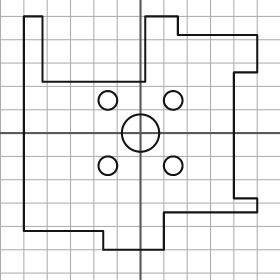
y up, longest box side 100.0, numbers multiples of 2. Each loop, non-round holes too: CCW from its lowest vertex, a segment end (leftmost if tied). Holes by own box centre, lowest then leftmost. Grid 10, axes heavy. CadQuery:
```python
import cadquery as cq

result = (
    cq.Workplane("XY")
    .moveTo(-16.0, -50.0)
    .lineTo(10.0, -50.0)
    .lineTo(10.0, -34.0)
    .lineTo(50.0, -34.0)
    .lineTo(50.0, -28.0)
    .lineTo(40.0, -28.0)
    .lineTo(40.0, 26.0)
    .lineTo(50.0, 26.0)
    .lineTo(50.0, 42.0)
    .lineTo(16.0, 42.0)
    .lineTo(16.0, 50.0)
    .lineTo(2.0, 50.0)
    .lineTo(2.0, 22.0)
    .lineTo(-42.0, 22.0)
    .lineTo(-42.0, 50.0)
    .lineTo(-50.0, 50.0)
    .lineTo(-50.0, -42.0)
    .lineTo(-16.0, -42.0)
    .close()
    .moveTo(-14.0, -14.0)
    .circle(4.0)
    .moveTo(14.0, -14.0)
    .circle(4.0)
    .moveTo(0.0, 0.0)
    .circle(8.0)
    .moveTo(-14.0, 14.0)
    .circle(4.0)
    .moveTo(14.0, 14.0)
    .circle(4.0)
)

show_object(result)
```